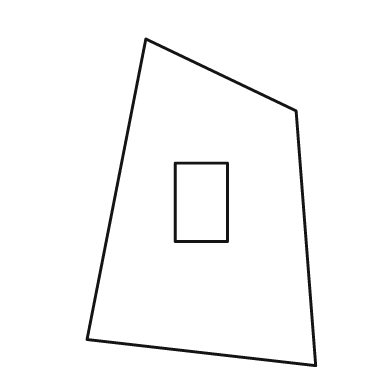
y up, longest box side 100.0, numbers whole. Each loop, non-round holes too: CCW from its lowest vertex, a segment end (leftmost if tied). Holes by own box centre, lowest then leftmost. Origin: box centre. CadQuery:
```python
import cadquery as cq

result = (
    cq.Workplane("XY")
    .moveTo(35.0, -50.0)
    .lineTo(29.0, 28.0)
    .lineTo(-17.0, 50.0)
    .lineTo(-35.0, -42.0)
    .close()
    .moveTo(-8.0, -12.0)
    .lineTo(8.0, -12.0)
    .lineTo(8.0, 12.0)
    .lineTo(-8.0, 12.0)
    .close()
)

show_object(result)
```